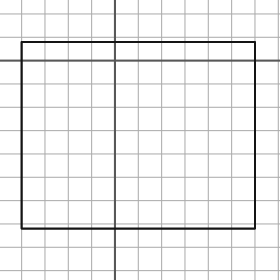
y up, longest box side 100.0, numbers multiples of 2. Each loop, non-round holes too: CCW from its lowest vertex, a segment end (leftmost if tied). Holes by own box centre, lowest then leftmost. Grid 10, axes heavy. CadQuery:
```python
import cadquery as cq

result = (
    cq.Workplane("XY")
    .moveTo(-40.0, -72.0)
    .lineTo(60.0, -72.0)
    .lineTo(60.0, 8.0)
    .lineTo(-40.0, 8.0)
    .close()
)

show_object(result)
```